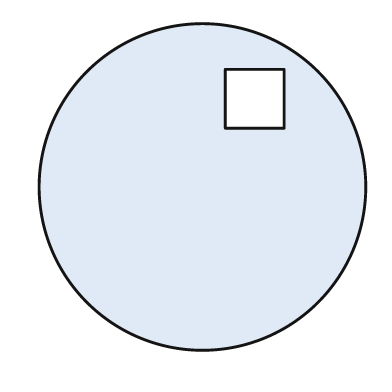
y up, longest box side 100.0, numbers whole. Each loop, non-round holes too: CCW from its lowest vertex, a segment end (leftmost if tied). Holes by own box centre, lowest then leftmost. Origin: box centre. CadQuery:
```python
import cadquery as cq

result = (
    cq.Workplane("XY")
    .moveTo(0.0, 0.0)
    .circle(50.0)
    .moveTo(7.0, 18.0)
    .lineTo(25.0, 18.0)
    .lineTo(25.0, 36.0)
    .lineTo(7.0, 36.0)
    .close()
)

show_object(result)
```